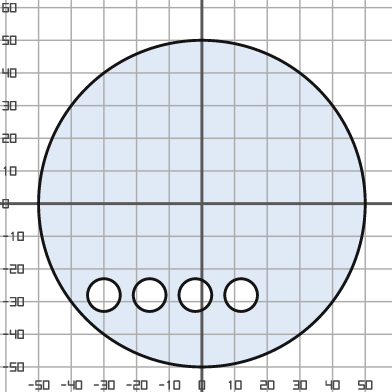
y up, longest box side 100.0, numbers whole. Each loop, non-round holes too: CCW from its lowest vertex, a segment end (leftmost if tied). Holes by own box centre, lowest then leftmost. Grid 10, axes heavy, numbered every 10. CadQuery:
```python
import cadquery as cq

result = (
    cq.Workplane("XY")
    .moveTo(0.0, 0.0)
    .circle(50.0)
    .moveTo(-30.0, -28.0)
    .circle(5.0)
    .moveTo(-16.0, -28.0)
    .circle(5.0)
    .moveTo(-2.0, -28.0)
    .circle(5.0)
    .moveTo(12.0, -28.0)
    .circle(5.0)
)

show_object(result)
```